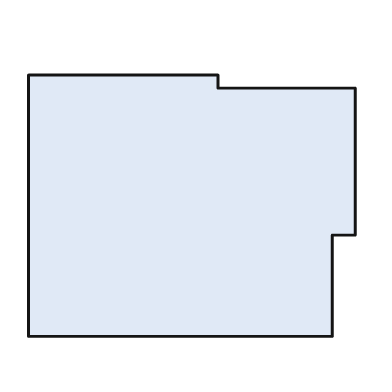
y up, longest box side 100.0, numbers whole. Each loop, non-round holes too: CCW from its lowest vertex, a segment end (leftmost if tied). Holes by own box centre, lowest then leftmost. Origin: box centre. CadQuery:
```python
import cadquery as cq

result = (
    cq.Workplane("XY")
    .moveTo(-50.0, -40.0)
    .lineTo(43.0, -40.0)
    .lineTo(43.0, -9.0)
    .lineTo(50.0, -9.0)
    .lineTo(50.0, 36.0)
    .lineTo(8.0, 36.0)
    .lineTo(8.0, 40.0)
    .lineTo(-50.0, 40.0)
    .close()
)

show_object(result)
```